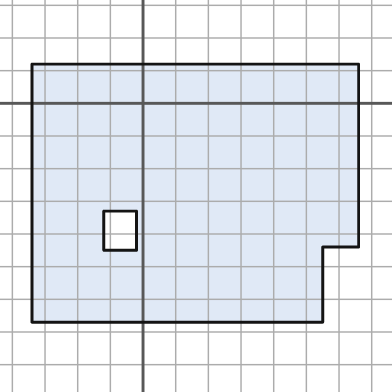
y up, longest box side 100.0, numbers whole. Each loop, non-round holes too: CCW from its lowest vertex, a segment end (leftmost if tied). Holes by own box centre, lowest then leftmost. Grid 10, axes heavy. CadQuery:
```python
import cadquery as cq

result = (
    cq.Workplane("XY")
    .moveTo(-34.0, -67.0)
    .lineTo(55.0, -67.0)
    .lineTo(55.0, -44.0)
    .lineTo(66.0, -44.0)
    .lineTo(66.0, 12.0)
    .lineTo(-34.0, 12.0)
    .close()
    .moveTo(-12.0, -45.0)
    .lineTo(-2.0, -45.0)
    .lineTo(-2.0, -33.0)
    .lineTo(-12.0, -33.0)
    .close()
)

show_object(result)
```